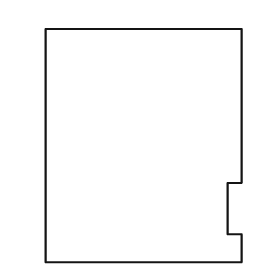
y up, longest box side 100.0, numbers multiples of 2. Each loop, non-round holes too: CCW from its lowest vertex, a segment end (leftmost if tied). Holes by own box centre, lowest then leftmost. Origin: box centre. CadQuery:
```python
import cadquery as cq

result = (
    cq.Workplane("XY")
    .moveTo(-42.0, -50.0)
    .lineTo(42.0, -50.0)
    .lineTo(42.0, -38.0)
    .lineTo(36.0, -38.0)
    .lineTo(36.0, -16.0)
    .lineTo(42.0, -16.0)
    .lineTo(42.0, 50.0)
    .lineTo(-42.0, 50.0)
    .close()
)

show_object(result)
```